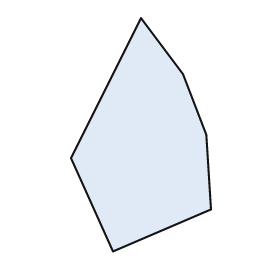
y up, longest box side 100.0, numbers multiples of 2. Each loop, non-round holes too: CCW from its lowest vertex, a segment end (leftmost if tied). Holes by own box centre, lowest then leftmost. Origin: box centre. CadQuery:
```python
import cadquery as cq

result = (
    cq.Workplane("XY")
    .moveTo(-12.0, -50.0)
    .lineTo(30.0, -32.0)
    .lineTo(28.0, 0.0)
    .lineTo(18.0, 26.0)
    .lineTo(0.0, 50.0)
    .lineTo(-30.0, -10.0)
    .close()
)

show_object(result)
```